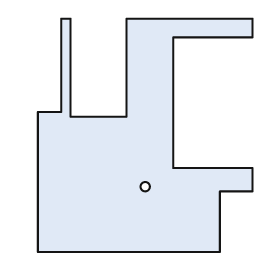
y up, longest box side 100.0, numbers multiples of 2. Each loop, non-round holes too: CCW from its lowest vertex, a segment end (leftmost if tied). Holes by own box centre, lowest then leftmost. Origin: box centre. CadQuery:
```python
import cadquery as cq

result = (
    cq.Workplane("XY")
    .moveTo(-46.0, -50.0)
    .lineTo(32.0, -50.0)
    .lineTo(32.0, -24.0)
    .lineTo(46.0, -24.0)
    .lineTo(46.0, -14.0)
    .lineTo(12.0, -14.0)
    .lineTo(12.0, 42.0)
    .lineTo(46.0, 42.0)
    .lineTo(46.0, 50.0)
    .lineTo(-8.0, 50.0)
    .lineTo(-8.0, 8.0)
    .lineTo(-32.0, 8.0)
    .lineTo(-32.0, 50.0)
    .lineTo(-36.0, 50.0)
    .lineTo(-36.0, 10.0)
    .lineTo(-46.0, 10.0)
    .close()
    .moveTo(0.0, -22.0)
    .circle(2.0)
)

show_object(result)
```